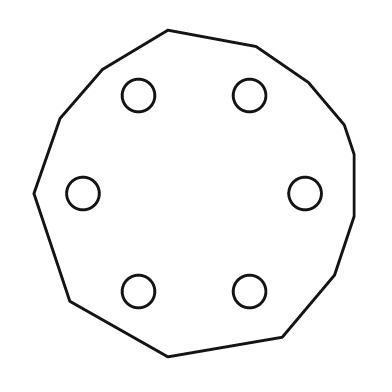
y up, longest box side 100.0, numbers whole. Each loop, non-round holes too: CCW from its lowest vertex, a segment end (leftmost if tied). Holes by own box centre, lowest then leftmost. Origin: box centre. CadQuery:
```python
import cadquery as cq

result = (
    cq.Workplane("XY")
    .moveTo(-8.0, -50.0)
    .lineTo(27.0, -44.0)
    .lineTo(43.0, -25.0)
    .lineTo(49.0, -7.0)
    .lineTo(49.0, 12.0)
    .lineTo(46.0, 21.0)
    .lineTo(35.0, 34.0)
    .lineTo(19.0, 45.0)
    .lineTo(-8.0, 50.0)
    .lineTo(-28.0, 38.0)
    .lineTo(-41.0, 23.0)
    .lineTo(-49.0, 0.0)
    .lineTo(-38.0, -33.0)
    .close()
    .moveTo(-17.0, -30.0)
    .circle(5.0)
    .moveTo(17.0, -30.0)
    .circle(5.0)
    .moveTo(-34.0, 0.0)
    .circle(5.0)
    .moveTo(34.0, 0.0)
    .circle(5.0)
    .moveTo(-17.0, 30.0)
    .circle(5.0)
    .moveTo(17.0, 30.0)
    .circle(5.0)
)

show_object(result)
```